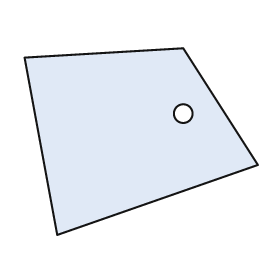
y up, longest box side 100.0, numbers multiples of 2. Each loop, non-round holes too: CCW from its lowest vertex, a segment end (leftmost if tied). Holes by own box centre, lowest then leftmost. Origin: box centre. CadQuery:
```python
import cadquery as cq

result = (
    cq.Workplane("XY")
    .moveTo(-36.0, -40.0)
    .lineTo(50.0, -10.0)
    .lineTo(18.0, 40.0)
    .lineTo(-50.0, 36.0)
    .close()
    .moveTo(18.0, 12.0)
    .circle(4.0)
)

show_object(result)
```